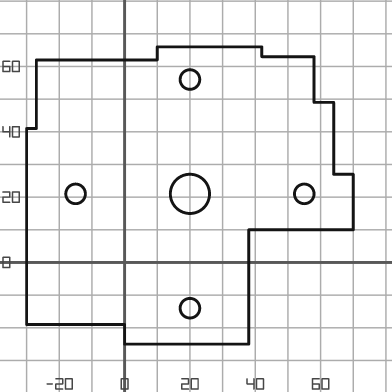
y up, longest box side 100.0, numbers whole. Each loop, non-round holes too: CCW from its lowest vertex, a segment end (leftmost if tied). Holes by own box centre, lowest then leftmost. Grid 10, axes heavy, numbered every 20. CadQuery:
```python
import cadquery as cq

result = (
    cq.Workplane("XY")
    .moveTo(0.0, -25.0)
    .lineTo(38.0, -25.0)
    .lineTo(38.0, 10.0)
    .lineTo(70.0, 10.0)
    .lineTo(70.0, 27.0)
    .lineTo(64.0, 27.0)
    .lineTo(64.0, 49.0)
    .lineTo(58.0, 49.0)
    .lineTo(58.0, 63.0)
    .lineTo(42.0, 63.0)
    .lineTo(42.0, 66.0)
    .lineTo(10.0, 66.0)
    .lineTo(10.0, 62.0)
    .lineTo(-27.0, 62.0)
    .lineTo(-27.0, 41.0)
    .lineTo(-30.0, 41.0)
    .lineTo(-30.0, -19.0)
    .lineTo(0.0, -19.0)
    .close()
    .moveTo(20.0, -14.0)
    .circle(3.0)
    .moveTo(-15.0, 21.0)
    .circle(3.0)
    .moveTo(20.0, 21.0)
    .circle(6.0)
    .moveTo(55.0, 21.0)
    .circle(3.0)
    .moveTo(20.0, 56.0)
    .circle(3.0)
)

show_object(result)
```